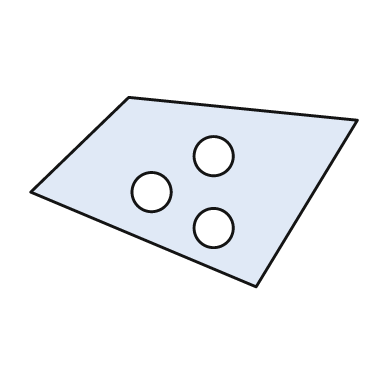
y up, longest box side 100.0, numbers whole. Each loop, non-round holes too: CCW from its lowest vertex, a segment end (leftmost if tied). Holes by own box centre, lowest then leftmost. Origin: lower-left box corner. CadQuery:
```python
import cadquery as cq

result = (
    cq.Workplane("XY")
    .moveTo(69.0, 0.0)
    .lineTo(100.0, 51.0)
    .lineTo(30.0, 58.0)
    .lineTo(0.0, 29.0)
    .close()
    .moveTo(56.0, 18.0)
    .circle(6.0)
    .moveTo(37.0, 29.0)
    .circle(6.0)
    .moveTo(56.0, 40.0)
    .circle(6.0)
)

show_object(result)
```